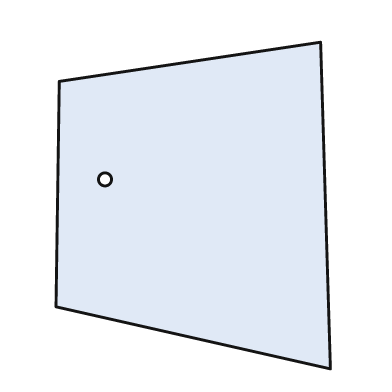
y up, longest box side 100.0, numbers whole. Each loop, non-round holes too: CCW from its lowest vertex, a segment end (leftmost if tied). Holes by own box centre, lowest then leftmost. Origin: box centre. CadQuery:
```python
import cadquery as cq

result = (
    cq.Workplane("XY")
    .moveTo(42.0, -50.0)
    .lineTo(39.0, 50.0)
    .lineTo(-41.0, 38.0)
    .lineTo(-42.0, -31.0)
    .close()
    .moveTo(-27.0, 8.0)
    .circle(2.0)
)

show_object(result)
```